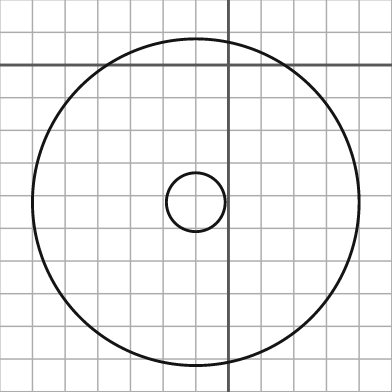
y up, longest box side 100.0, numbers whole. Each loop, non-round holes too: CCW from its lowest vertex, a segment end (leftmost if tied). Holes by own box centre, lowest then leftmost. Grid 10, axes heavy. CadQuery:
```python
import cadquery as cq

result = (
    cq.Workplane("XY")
    .moveTo(-10.0, -42.0)
    .circle(50.0)
    .moveTo(-10.0, -42.0)
    .circle(9.0)
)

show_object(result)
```